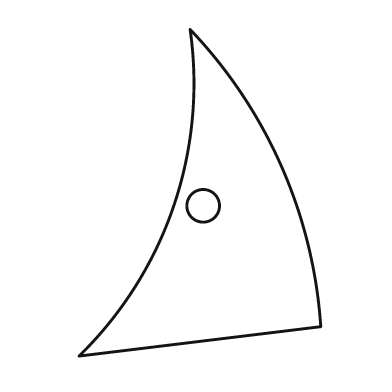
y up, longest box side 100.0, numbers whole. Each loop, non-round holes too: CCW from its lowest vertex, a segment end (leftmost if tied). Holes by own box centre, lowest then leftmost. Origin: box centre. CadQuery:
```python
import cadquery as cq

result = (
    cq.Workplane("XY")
    .moveTo(-37.0, -50.0)
    .lineTo(37.0, -41.0)
    .threePointArc((25.0, 8.0), (-3.0, 50.0))
    .threePointArc((-8.0, -4.0), (-37.0, -50.0))
    .close()
    .moveTo(1.0, -4.0)
    .circle(5.0)
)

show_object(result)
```